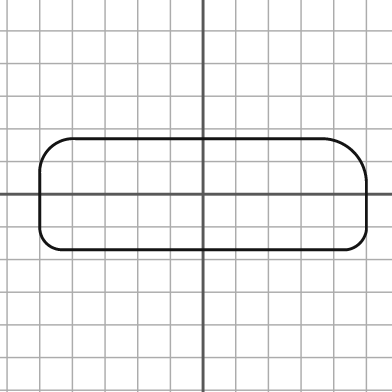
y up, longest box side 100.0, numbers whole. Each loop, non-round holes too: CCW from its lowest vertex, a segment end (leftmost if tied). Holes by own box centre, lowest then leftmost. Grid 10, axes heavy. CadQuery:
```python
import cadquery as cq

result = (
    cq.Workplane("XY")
    .moveTo(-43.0, -17.0)
    .lineTo(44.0, -17.0)
    .threePointArc((48.0, -15.0), (50.0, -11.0))
    .lineTo(50.0, 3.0)
    .threePointArc((46.0, 13.0), (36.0, 17.0))
    .lineTo(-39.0, 17.0)
    .threePointArc((-47.0, 14.0), (-50.0, 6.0))
    .lineTo(-50.0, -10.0)
    .threePointArc((-48.0, -15.0), (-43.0, -17.0))
    .close()
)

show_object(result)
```